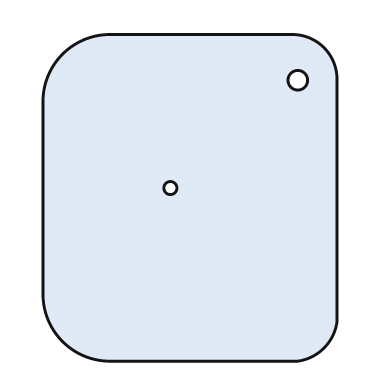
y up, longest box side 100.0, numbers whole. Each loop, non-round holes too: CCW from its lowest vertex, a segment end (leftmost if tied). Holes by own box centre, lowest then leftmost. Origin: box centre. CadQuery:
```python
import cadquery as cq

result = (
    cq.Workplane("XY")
    .moveTo(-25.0, -50.0)
    .lineTo(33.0, -50.0)
    .threePointArc((41.0, -46.0), (45.0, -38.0))
    .lineTo(45.0, 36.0)
    .threePointArc((41.0, 46.0), (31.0, 50.0))
    .lineTo(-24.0, 50.0)
    .threePointArc((-39.0, 44.0), (-45.0, 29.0))
    .lineTo(-45.0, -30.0)
    .threePointArc((-39.0, -44.0), (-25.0, -50.0))
    .close()
    .moveTo(-6.0, 3.0)
    .circle(2.0)
    .moveTo(33.0, 36.0)
    .circle(3.0)
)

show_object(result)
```